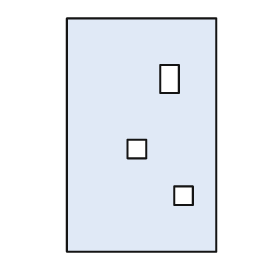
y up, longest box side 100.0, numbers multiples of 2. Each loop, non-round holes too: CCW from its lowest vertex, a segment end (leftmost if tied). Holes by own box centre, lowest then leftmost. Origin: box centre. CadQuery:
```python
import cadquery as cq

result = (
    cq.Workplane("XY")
    .moveTo(-32.0, -50.0)
    .lineTo(32.0, -50.0)
    .lineTo(32.0, 50.0)
    .lineTo(-32.0, 50.0)
    .close()
    .moveTo(14.0, -30.0)
    .lineTo(22.0, -30.0)
    .lineTo(22.0, -22.0)
    .lineTo(14.0, -22.0)
    .close()
    .moveTo(-6.0, -10.0)
    .lineTo(2.0, -10.0)
    .lineTo(2.0, -2.0)
    .lineTo(-6.0, -2.0)
    .close()
    .moveTo(8.0, 18.0)
    .lineTo(16.0, 18.0)
    .lineTo(16.0, 30.0)
    .lineTo(8.0, 30.0)
    .close()
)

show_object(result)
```